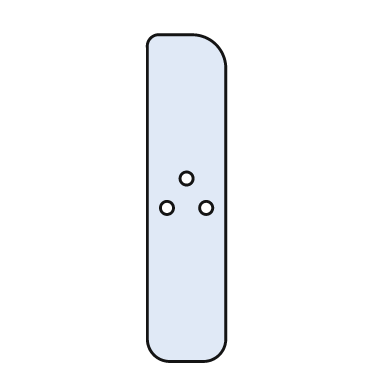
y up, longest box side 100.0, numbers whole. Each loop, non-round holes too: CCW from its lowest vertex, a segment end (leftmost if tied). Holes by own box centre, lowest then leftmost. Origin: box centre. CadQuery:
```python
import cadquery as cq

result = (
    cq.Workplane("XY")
    .moveTo(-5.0, -50.0)
    .lineTo(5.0, -50.0)
    .threePointArc((10.0, -48.0), (12.0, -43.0))
    .lineTo(12.0, 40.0)
    .threePointArc((9.0, 47.0), (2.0, 50.0))
    .lineTo(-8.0, 50.0)
    .threePointArc((-11.0, 49.0), (-12.0, 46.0))
    .lineTo(-12.0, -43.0)
    .threePointArc((-10.0, -48.0), (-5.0, -50.0))
    .close()
    .moveTo(-6.0, -3.0)
    .circle(2.0)
    .moveTo(6.0, -3.0)
    .circle(2.0)
    .moveTo(0.0, 6.0)
    .circle(2.0)
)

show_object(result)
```